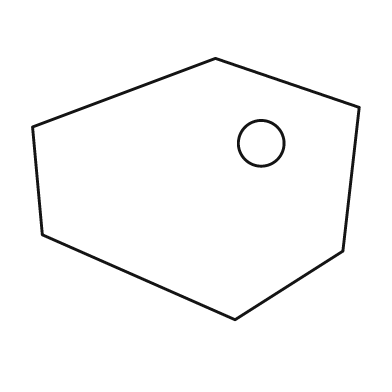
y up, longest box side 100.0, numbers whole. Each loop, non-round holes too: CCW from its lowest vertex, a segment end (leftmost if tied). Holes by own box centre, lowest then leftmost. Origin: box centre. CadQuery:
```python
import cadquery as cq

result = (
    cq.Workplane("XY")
    .moveTo(12.0, -40.0)
    .lineTo(45.0, -19.0)
    .lineTo(50.0, 25.0)
    .lineTo(6.0, 40.0)
    .lineTo(-50.0, 19.0)
    .lineTo(-47.0, -14.0)
    .close()
    .moveTo(20.0, 14.0)
    .circle(7.0)
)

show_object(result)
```